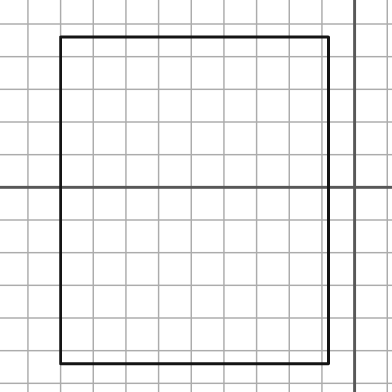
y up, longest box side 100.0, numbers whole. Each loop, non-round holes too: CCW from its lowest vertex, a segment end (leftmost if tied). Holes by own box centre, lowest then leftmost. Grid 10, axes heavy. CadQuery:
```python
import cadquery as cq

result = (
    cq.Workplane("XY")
    .moveTo(-90.0, -54.0)
    .lineTo(-8.0, -54.0)
    .lineTo(-8.0, 46.0)
    .lineTo(-90.0, 46.0)
    .close()
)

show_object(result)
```